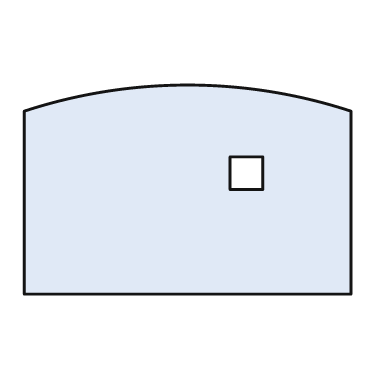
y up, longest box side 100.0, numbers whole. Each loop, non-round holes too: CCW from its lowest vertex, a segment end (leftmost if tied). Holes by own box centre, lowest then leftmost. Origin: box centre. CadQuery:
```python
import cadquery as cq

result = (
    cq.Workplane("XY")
    .moveTo(-50.0, -32.0)
    .lineTo(50.0, -32.0)
    .lineTo(50.0, 24.0)
    .threePointArc((0.0, 32.0), (-50.0, 24.0))
    .close()
    .moveTo(13.0, 0.0)
    .lineTo(23.0, 0.0)
    .lineTo(23.0, 10.0)
    .lineTo(13.0, 10.0)
    .close()
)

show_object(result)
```